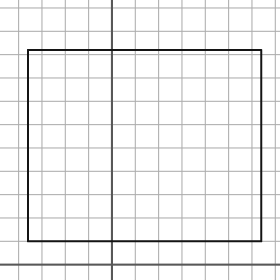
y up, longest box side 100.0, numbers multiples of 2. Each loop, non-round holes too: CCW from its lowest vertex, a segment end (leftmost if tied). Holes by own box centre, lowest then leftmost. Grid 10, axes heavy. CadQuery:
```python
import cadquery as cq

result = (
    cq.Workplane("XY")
    .moveTo(-36.0, 10.0)
    .lineTo(64.0, 10.0)
    .lineTo(64.0, 92.0)
    .lineTo(-36.0, 92.0)
    .close()
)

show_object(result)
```